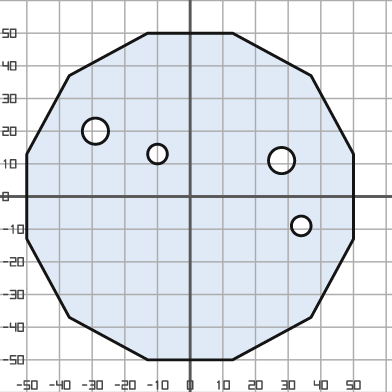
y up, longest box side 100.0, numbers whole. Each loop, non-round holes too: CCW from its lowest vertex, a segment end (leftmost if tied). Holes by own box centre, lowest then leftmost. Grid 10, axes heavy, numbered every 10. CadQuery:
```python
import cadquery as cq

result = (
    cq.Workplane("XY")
    .moveTo(-13.0, -50.0)
    .lineTo(13.0, -50.0)
    .lineTo(37.0, -37.0)
    .lineTo(50.0, -13.0)
    .lineTo(50.0, 13.0)
    .lineTo(37.0, 37.0)
    .lineTo(13.0, 50.0)
    .lineTo(-13.0, 50.0)
    .lineTo(-37.0, 37.0)
    .lineTo(-50.0, 13.0)
    .lineTo(-50.0, -13.0)
    .lineTo(-37.0, -37.0)
    .close()
    .moveTo(34.0, -9.0)
    .circle(3.0)
    .moveTo(28.0, 11.0)
    .circle(4.0)
    .moveTo(-10.0, 13.0)
    .circle(3.0)
    .moveTo(-29.0, 20.0)
    .circle(4.0)
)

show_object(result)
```